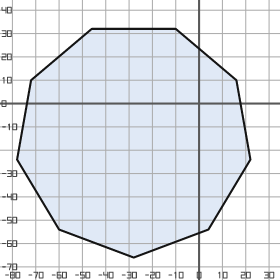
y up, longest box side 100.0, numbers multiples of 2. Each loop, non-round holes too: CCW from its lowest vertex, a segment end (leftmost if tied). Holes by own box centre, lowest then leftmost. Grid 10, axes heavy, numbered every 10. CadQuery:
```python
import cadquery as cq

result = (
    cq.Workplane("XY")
    .moveTo(-28.0, -66.0)
    .lineTo(4.0, -54.0)
    .lineTo(22.0, -24.0)
    .lineTo(16.0, 10.0)
    .lineTo(-10.0, 32.0)
    .lineTo(-46.0, 32.0)
    .lineTo(-72.0, 10.0)
    .lineTo(-78.0, -24.0)
    .lineTo(-60.0, -54.0)
    .close()
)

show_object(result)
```